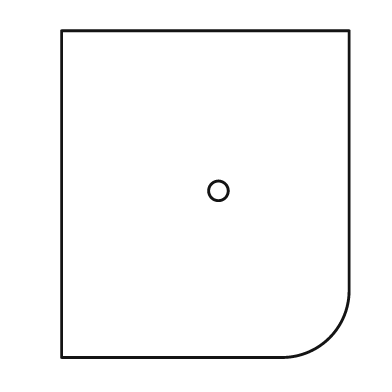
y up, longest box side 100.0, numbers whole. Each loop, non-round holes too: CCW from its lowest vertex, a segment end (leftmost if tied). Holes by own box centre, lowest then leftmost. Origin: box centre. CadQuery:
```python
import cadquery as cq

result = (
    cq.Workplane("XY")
    .moveTo(-44.0, -50.0)
    .lineTo(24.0, -50.0)
    .threePointArc((38.0, -44.0), (44.0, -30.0))
    .lineTo(44.0, 50.0)
    .lineTo(-44.0, 50.0)
    .close()
    .moveTo(4.0, 1.0)
    .circle(3.0)
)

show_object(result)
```